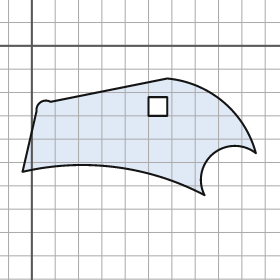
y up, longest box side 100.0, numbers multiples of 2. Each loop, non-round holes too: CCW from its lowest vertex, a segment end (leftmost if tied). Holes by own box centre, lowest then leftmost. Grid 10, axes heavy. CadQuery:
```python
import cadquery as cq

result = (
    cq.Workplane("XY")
    .moveTo(74.0, -64.0)
    .threePointArc((78.0, -46.0), (96.0, -46.0))
    .threePointArc((82.0, -24.0), (58.0, -14.0))
    .lineTo(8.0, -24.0)
    .threePointArc((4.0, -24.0), (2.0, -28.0))
    .lineTo(-4.0, -54.0)
    .threePointArc((36.0, -52.0), (74.0, -64.0))
    .close()
    .moveTo(50.0, -30.0)
    .lineTo(58.0, -30.0)
    .lineTo(58.0, -22.0)
    .lineTo(50.0, -22.0)
    .close()
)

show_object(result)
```